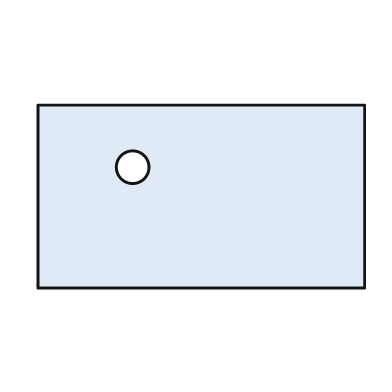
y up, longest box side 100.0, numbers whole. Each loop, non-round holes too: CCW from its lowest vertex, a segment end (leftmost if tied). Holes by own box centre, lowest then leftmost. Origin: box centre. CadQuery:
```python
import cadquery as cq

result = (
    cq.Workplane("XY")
    .moveTo(-50.0, -28.0)
    .lineTo(50.0, -28.0)
    .lineTo(50.0, 28.0)
    .lineTo(-50.0, 28.0)
    .close()
    .moveTo(-21.0, 9.0)
    .circle(5.0)
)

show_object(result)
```